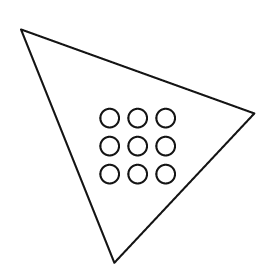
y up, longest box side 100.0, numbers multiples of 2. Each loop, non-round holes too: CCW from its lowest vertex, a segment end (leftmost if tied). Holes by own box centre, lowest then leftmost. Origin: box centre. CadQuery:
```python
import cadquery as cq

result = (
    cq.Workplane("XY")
    .moveTo(-10.0, -50.0)
    .lineTo(50.0, 14.0)
    .lineTo(-50.0, 50.0)
    .close()
    .moveTo(-12.0, -12.0)
    .circle(4.0)
    .moveTo(0.0, -12.0)
    .circle(4.0)
    .moveTo(12.0, -12.0)
    .circle(4.0)
    .moveTo(-12.0, 0.0)
    .circle(4.0)
    .moveTo(0.0, 0.0)
    .circle(4.0)
    .moveTo(12.0, 0.0)
    .circle(4.0)
    .moveTo(-12.0, 12.0)
    .circle(4.0)
    .moveTo(0.0, 12.0)
    .circle(4.0)
    .moveTo(12.0, 12.0)
    .circle(4.0)
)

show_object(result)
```